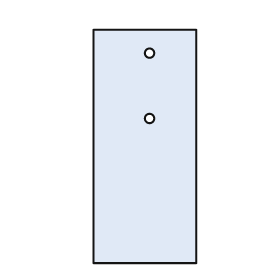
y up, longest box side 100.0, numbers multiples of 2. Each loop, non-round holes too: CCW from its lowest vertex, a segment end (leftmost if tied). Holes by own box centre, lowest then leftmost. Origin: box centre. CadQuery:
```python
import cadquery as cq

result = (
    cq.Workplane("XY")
    .moveTo(-22.0, -50.0)
    .lineTo(22.0, -50.0)
    .lineTo(22.0, 50.0)
    .lineTo(-22.0, 50.0)
    .close()
    .moveTo(2.0, 12.0)
    .circle(2.0)
    .moveTo(2.0, 40.0)
    .circle(2.0)
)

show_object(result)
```